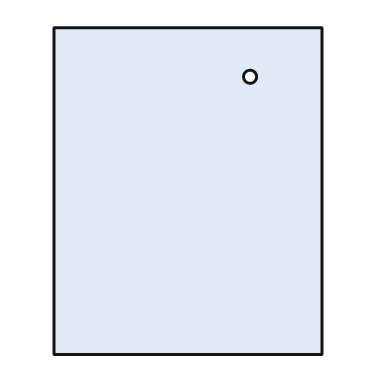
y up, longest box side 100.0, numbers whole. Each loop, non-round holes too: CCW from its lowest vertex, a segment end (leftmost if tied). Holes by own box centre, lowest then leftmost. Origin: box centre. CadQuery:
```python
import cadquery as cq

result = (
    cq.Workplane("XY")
    .moveTo(-41.0, -50.0)
    .lineTo(41.0, -50.0)
    .lineTo(41.0, 50.0)
    .lineTo(-41.0, 50.0)
    .close()
    .moveTo(19.0, 35.0)
    .circle(2.0)
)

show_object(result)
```